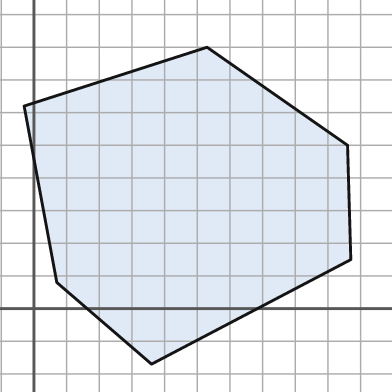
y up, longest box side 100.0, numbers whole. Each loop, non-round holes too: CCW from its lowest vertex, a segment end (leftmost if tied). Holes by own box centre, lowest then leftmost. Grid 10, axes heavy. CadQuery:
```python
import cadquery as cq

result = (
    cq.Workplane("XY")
    .moveTo(36.0, -17.0)
    .lineTo(97.0, 15.0)
    .lineTo(96.0, 50.0)
    .lineTo(53.0, 80.0)
    .lineTo(-3.0, 62.0)
    .lineTo(7.0, 8.0)
    .close()
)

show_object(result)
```